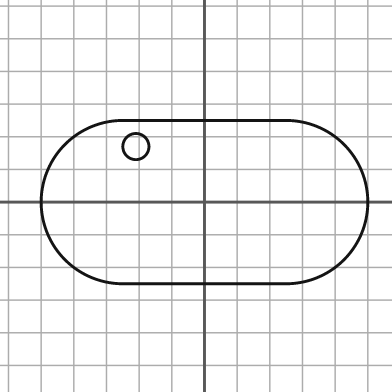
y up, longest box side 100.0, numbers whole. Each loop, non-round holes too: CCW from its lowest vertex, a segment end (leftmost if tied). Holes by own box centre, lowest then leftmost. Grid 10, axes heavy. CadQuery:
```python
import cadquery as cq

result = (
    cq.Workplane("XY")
    .moveTo(-25.0, -25.0)
    .lineTo(25.0, -25.0)
    .threePointArc((50.0, 0.0), (25.0, 25.0))
    .lineTo(-25.0, 25.0)
    .threePointArc((-50.0, 0.0), (-25.0, -25.0))
    .close()
    .moveTo(-21.0, 17.0)
    .circle(4.0)
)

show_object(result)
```